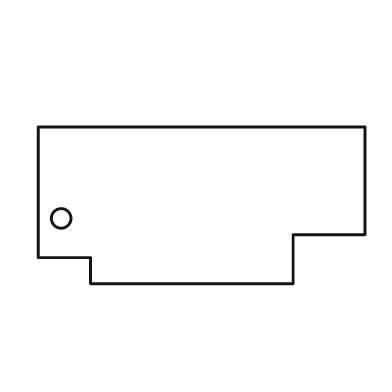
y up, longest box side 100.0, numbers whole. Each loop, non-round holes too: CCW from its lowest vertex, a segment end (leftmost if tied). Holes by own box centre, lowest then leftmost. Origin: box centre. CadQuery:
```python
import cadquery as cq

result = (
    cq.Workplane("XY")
    .moveTo(-34.0, -24.0)
    .lineTo(28.0, -24.0)
    .lineTo(28.0, -9.0)
    .lineTo(50.0, -9.0)
    .lineTo(50.0, 24.0)
    .lineTo(-50.0, 24.0)
    .lineTo(-50.0, -16.0)
    .lineTo(-34.0, -16.0)
    .close()
    .moveTo(-43.0, -4.0)
    .circle(3.0)
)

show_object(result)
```